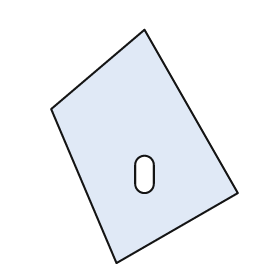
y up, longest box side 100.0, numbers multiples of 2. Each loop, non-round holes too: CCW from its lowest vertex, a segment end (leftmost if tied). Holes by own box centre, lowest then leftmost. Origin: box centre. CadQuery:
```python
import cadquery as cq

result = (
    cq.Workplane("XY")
    .moveTo(-12.0, -50.0)
    .lineTo(40.0, -20.0)
    .lineTo(0.0, 50.0)
    .lineTo(-40.0, 16.0)
    .close()
    .moveTo(-4.0, -16.0)
    .threePointArc((0.0, -20.0), (4.0, -16.0))
    .lineTo(4.0, -8.0)
    .threePointArc((0.0, -4.0), (-4.0, -8.0))
    .close()
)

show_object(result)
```